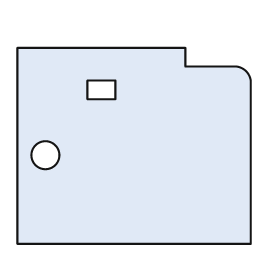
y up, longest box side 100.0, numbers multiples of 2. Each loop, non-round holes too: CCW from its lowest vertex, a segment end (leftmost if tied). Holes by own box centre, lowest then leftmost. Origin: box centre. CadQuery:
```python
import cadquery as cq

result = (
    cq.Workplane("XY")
    .moveTo(-50.0, -42.0)
    .lineTo(50.0, -42.0)
    .lineTo(50.0, 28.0)
    .threePointArc((48.0, 32.0), (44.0, 34.0))
    .lineTo(22.0, 34.0)
    .lineTo(22.0, 42.0)
    .lineTo(-50.0, 42.0)
    .close()
    .moveTo(-38.0, -4.0)
    .circle(6.0)
    .moveTo(-20.0, 20.0)
    .lineTo(-8.0, 20.0)
    .lineTo(-8.0, 28.0)
    .lineTo(-20.0, 28.0)
    .close()
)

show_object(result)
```